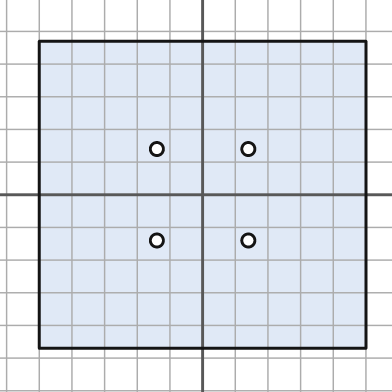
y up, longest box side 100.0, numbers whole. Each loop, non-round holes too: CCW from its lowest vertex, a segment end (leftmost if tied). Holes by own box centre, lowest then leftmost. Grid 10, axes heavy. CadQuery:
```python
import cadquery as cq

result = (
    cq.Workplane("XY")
    .moveTo(-50.0, -47.0)
    .lineTo(50.0, -47.0)
    .lineTo(50.0, 47.0)
    .lineTo(-50.0, 47.0)
    .close()
    .moveTo(-14.0, -14.0)
    .circle(2.0)
    .moveTo(14.0, -14.0)
    .circle(2.0)
    .moveTo(-14.0, 14.0)
    .circle(2.0)
    .moveTo(14.0, 14.0)
    .circle(2.0)
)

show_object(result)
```